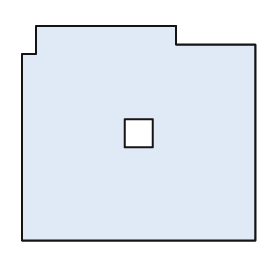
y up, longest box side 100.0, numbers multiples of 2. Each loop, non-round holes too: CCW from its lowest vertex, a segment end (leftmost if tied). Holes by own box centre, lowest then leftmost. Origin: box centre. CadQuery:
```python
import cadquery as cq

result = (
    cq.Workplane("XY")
    .moveTo(-50.0, -46.0)
    .lineTo(50.0, -46.0)
    .lineTo(50.0, 38.0)
    .lineTo(16.0, 38.0)
    .lineTo(16.0, 46.0)
    .lineTo(-44.0, 46.0)
    .lineTo(-44.0, 34.0)
    .lineTo(-50.0, 34.0)
    .close()
    .moveTo(-6.0, -6.0)
    .lineTo(6.0, -6.0)
    .lineTo(6.0, 6.0)
    .lineTo(-6.0, 6.0)
    .close()
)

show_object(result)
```